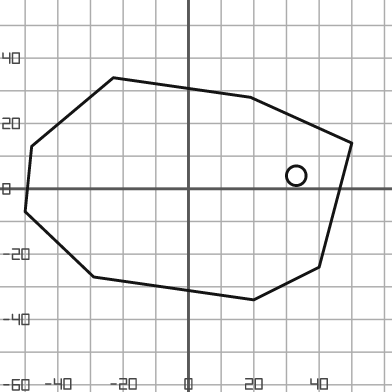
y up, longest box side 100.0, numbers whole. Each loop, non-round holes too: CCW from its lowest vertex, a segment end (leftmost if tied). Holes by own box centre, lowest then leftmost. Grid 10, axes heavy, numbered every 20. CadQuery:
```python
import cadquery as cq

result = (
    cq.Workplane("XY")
    .moveTo(20.0, -34.0)
    .lineTo(40.0, -24.0)
    .lineTo(50.0, 14.0)
    .lineTo(19.0, 28.0)
    .lineTo(-23.0, 34.0)
    .lineTo(-48.0, 13.0)
    .lineTo(-50.0, -7.0)
    .lineTo(-29.0, -27.0)
    .close()
    .moveTo(33.0, 4.0)
    .circle(3.0)
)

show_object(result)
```